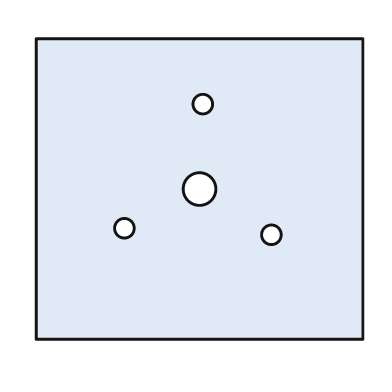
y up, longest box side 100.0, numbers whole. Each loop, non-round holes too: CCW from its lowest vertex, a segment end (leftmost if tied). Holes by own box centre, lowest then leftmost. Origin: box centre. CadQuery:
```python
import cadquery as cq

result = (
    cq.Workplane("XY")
    .moveTo(-50.0, -46.0)
    .lineTo(50.0, -46.0)
    .lineTo(50.0, 46.0)
    .lineTo(-50.0, 46.0)
    .close()
    .moveTo(22.0, -14.0)
    .circle(3.0)
    .moveTo(-23.0, -12.0)
    .circle(3.0)
    .moveTo(0.0, 0.0)
    .circle(5.0)
    .moveTo(1.0, 26.0)
    .circle(3.0)
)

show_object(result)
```